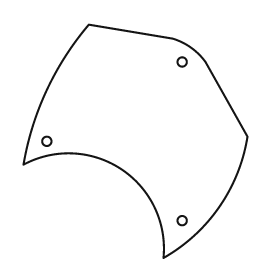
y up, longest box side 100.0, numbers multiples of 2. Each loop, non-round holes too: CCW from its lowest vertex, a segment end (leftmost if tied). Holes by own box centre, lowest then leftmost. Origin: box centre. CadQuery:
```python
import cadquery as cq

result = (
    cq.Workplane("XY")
    .moveTo(12.0, -50.0)
    .threePointArc((36.0, -28.0), (48.0, 2.0))
    .lineTo(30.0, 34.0)
    .threePointArc((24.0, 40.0), (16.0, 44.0))
    .lineTo(-20.0, 50.0)
    .threePointArc((-38.0, 22.0), (-48.0, -10.0))
    .threePointArc((-6.0, -12.0), (12.0, -50.0))
    .close()
    .moveTo(20.0, -34.0)
    .circle(2.0)
    .moveTo(-38.0, 0.0)
    .circle(2.0)
    .moveTo(20.0, 34.0)
    .circle(2.0)
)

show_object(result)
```